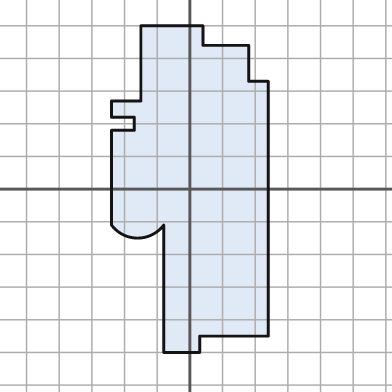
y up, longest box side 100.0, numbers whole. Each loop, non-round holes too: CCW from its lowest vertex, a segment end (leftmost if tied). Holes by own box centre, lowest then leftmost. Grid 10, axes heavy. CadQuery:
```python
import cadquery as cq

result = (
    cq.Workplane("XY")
    .moveTo(-8.0, -50.0)
    .lineTo(3.0, -50.0)
    .lineTo(3.0, -45.0)
    .lineTo(24.0, -45.0)
    .lineTo(24.0, 33.0)
    .lineTo(18.0, 33.0)
    .lineTo(18.0, 44.0)
    .lineTo(4.0, 44.0)
    .lineTo(4.0, 50.0)
    .lineTo(-15.0, 50.0)
    .lineTo(-15.0, 27.0)
    .lineTo(-24.0, 27.0)
    .lineTo(-24.0, 22.0)
    .lineTo(-17.0, 22.0)
    .lineTo(-17.0, 18.0)
    .lineTo(-24.0, 18.0)
    .lineTo(-24.0, -11.0)
    .threePointArc((-16.0, -15.0), (-8.0, -11.0))
    .close()
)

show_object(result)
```